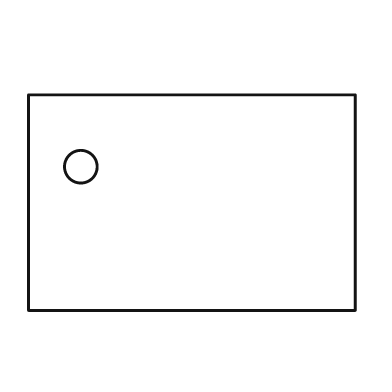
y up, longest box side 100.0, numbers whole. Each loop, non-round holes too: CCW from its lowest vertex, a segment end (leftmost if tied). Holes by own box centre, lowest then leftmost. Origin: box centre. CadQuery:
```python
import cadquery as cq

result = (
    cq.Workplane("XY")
    .moveTo(-50.0, -33.0)
    .lineTo(50.0, -33.0)
    .lineTo(50.0, 33.0)
    .lineTo(-50.0, 33.0)
    .close()
    .moveTo(-34.0, 11.0)
    .circle(5.0)
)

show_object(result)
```